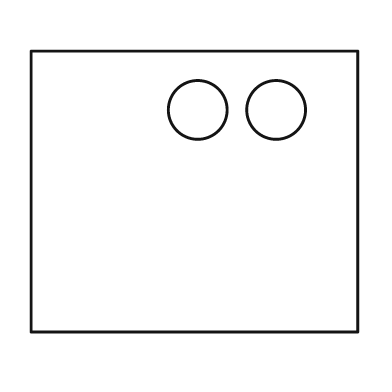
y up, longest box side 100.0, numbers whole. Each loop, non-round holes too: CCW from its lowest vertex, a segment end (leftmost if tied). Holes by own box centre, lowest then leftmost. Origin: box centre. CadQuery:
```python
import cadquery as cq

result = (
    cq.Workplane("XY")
    .moveTo(-50.0, -43.0)
    .lineTo(50.0, -43.0)
    .lineTo(50.0, 43.0)
    .lineTo(-50.0, 43.0)
    .close()
    .moveTo(1.0, 25.0)
    .circle(9.0)
    .moveTo(25.0, 25.0)
    .circle(9.0)
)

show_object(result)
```